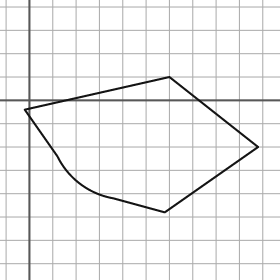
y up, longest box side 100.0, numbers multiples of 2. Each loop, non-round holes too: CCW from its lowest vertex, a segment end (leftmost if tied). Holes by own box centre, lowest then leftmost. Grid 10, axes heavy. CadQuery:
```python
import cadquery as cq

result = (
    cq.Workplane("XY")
    .moveTo(58.0, -48.0)
    .lineTo(98.0, -20.0)
    .lineTo(60.0, 10.0)
    .lineTo(-2.0, -4.0)
    .lineTo(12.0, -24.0)
    .threePointArc((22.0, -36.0), (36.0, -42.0))
    .close()
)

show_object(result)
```